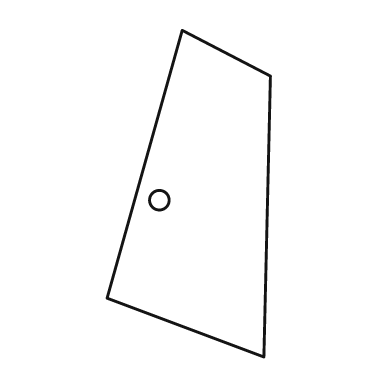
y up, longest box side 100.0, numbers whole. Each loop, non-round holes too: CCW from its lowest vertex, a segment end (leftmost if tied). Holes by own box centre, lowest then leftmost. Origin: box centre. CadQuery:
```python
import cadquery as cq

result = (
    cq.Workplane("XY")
    .moveTo(23.0, -50.0)
    .lineTo(25.0, 36.0)
    .lineTo(-2.0, 50.0)
    .lineTo(-25.0, -32.0)
    .close()
    .moveTo(-9.0, -2.0)
    .circle(3.0)
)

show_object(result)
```